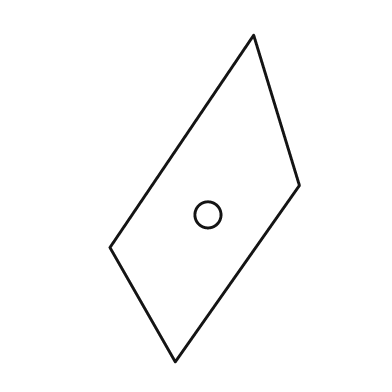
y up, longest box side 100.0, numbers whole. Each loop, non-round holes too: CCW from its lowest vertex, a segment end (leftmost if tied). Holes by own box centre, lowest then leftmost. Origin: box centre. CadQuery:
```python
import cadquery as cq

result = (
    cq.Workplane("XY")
    .moveTo(-9.0, -50.0)
    .lineTo(29.0, 4.0)
    .lineTo(15.0, 50.0)
    .lineTo(-29.0, -15.0)
    .close()
    .moveTo(1.0, -5.0)
    .circle(4.0)
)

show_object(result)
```